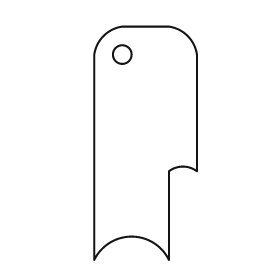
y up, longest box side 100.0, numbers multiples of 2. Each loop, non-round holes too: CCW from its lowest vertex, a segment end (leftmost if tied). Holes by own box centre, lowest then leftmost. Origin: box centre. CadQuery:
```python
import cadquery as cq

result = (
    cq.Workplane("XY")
    .moveTo(-22.0, -50.0)
    .threePointArc((-6.0, -40.0), (10.0, -50.0))
    .lineTo(10.0, -12.0)
    .threePointArc((16.0, -10.0), (22.0, -12.0))
    .lineTo(22.0, 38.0)
    .threePointArc((18.0, 46.0), (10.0, 50.0))
    .lineTo(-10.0, 50.0)
    .threePointArc((-18.0, 46.0), (-22.0, 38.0))
    .close()
    .moveTo(-10.0, 38.0)
    .circle(4.0)
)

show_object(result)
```